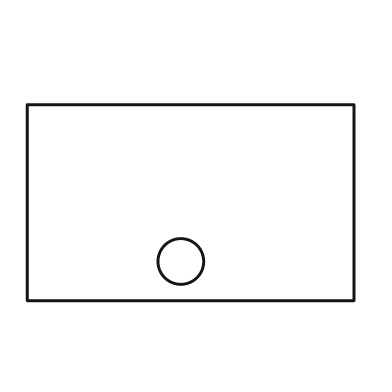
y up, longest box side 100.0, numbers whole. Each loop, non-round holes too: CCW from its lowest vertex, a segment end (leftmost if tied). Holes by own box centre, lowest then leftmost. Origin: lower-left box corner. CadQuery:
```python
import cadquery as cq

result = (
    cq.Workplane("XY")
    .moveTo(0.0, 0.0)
    .lineTo(100.0, 0.0)
    .lineTo(100.0, 60.0)
    .lineTo(0.0, 60.0)
    .close()
    .moveTo(47.0, 12.0)
    .circle(7.0)
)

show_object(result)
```